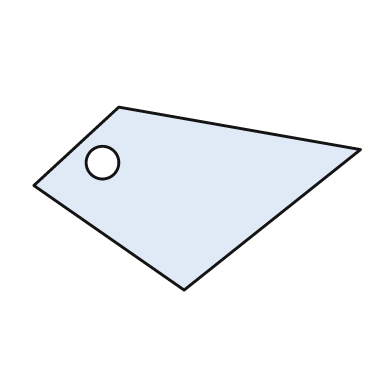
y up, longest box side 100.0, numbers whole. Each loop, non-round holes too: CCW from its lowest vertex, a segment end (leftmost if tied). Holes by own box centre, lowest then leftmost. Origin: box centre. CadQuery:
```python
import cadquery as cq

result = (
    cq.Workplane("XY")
    .moveTo(-4.0, -28.0)
    .lineTo(50.0, 15.0)
    .lineTo(-24.0, 28.0)
    .lineTo(-50.0, 4.0)
    .close()
    .moveTo(-29.0, 11.0)
    .circle(5.0)
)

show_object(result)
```